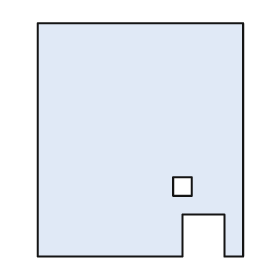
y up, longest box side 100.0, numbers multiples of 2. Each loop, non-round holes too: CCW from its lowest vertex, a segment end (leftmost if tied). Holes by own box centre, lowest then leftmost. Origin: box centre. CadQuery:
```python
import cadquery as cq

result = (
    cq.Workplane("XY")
    .moveTo(-44.0, -50.0)
    .lineTo(18.0, -50.0)
    .lineTo(18.0, -32.0)
    .lineTo(36.0, -32.0)
    .lineTo(36.0, -50.0)
    .lineTo(44.0, -50.0)
    .lineTo(44.0, 50.0)
    .lineTo(-44.0, 50.0)
    .close()
    .moveTo(14.0, -24.0)
    .lineTo(22.0, -24.0)
    .lineTo(22.0, -16.0)
    .lineTo(14.0, -16.0)
    .close()
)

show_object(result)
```